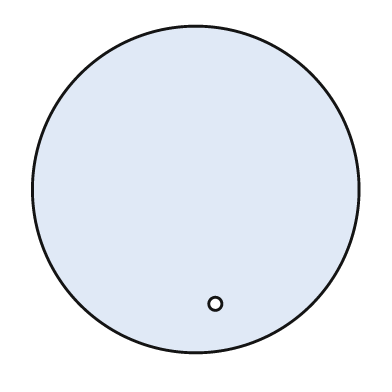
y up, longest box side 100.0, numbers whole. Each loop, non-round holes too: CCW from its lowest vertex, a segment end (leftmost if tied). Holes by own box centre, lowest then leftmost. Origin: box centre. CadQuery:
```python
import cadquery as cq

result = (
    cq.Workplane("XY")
    .moveTo(0.0, 0.0)
    .circle(50.0)
    .moveTo(6.0, -35.0)
    .circle(2.0)
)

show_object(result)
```